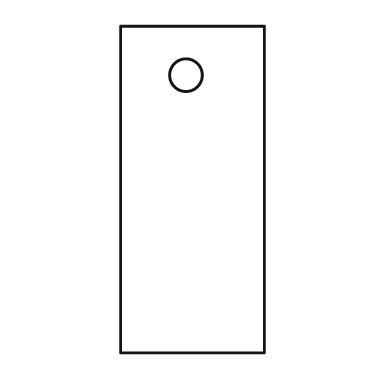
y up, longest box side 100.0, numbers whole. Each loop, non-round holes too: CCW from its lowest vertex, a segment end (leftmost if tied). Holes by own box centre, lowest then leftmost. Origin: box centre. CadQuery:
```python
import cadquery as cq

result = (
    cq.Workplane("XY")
    .moveTo(-22.0, -50.0)
    .lineTo(22.0, -50.0)
    .lineTo(22.0, 50.0)
    .lineTo(-22.0, 50.0)
    .close()
    .moveTo(-2.0, 35.0)
    .circle(5.0)
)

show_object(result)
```